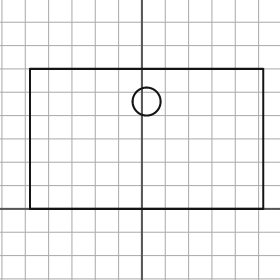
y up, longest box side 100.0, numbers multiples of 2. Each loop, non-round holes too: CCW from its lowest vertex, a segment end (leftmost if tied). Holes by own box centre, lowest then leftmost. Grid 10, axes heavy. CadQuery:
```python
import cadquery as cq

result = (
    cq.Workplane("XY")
    .moveTo(-48.0, 0.0)
    .lineTo(52.0, 0.0)
    .lineTo(52.0, 60.0)
    .lineTo(-48.0, 60.0)
    .close()
    .moveTo(2.0, 46.0)
    .circle(6.0)
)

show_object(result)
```